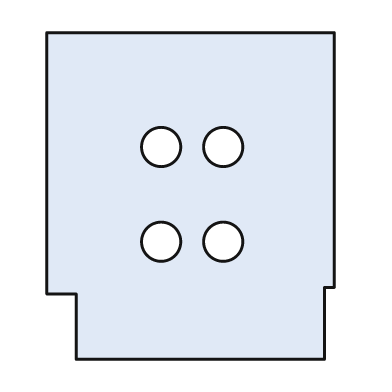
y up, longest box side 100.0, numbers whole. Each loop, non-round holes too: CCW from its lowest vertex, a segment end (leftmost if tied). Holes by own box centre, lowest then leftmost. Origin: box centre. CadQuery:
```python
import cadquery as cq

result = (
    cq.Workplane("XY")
    .moveTo(-35.0, -50.0)
    .lineTo(41.0, -50.0)
    .lineTo(41.0, -28.0)
    .lineTo(44.0, -28.0)
    .lineTo(44.0, 50.0)
    .lineTo(-44.0, 50.0)
    .lineTo(-44.0, -30.0)
    .lineTo(-35.0, -30.0)
    .close()
    .moveTo(-9.0, -14.0)
    .circle(6.0)
    .moveTo(10.0, -14.0)
    .circle(6.0)
    .moveTo(-9.0, 15.0)
    .circle(6.0)
    .moveTo(10.0, 15.0)
    .circle(6.0)
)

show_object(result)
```